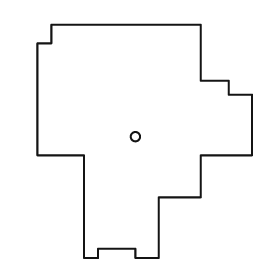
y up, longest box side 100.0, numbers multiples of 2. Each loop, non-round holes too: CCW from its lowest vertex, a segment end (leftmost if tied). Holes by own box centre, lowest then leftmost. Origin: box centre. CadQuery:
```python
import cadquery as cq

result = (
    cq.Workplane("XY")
    .moveTo(-26.0, -50.0)
    .lineTo(-20.0, -50.0)
    .lineTo(-20.0, -46.0)
    .lineTo(-4.0, -46.0)
    .lineTo(-4.0, -50.0)
    .lineTo(6.0, -50.0)
    .lineTo(6.0, -24.0)
    .lineTo(24.0, -24.0)
    .lineTo(24.0, -6.0)
    .lineTo(46.0, -6.0)
    .lineTo(46.0, 20.0)
    .lineTo(36.0, 20.0)
    .lineTo(36.0, 26.0)
    .lineTo(24.0, 26.0)
    .lineTo(24.0, 50.0)
    .lineTo(-40.0, 50.0)
    .lineTo(-40.0, 42.0)
    .lineTo(-46.0, 42.0)
    .lineTo(-46.0, -6.0)
    .lineTo(-26.0, -6.0)
    .close()
    .moveTo(-4.0, 2.0)
    .circle(2.0)
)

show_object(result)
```